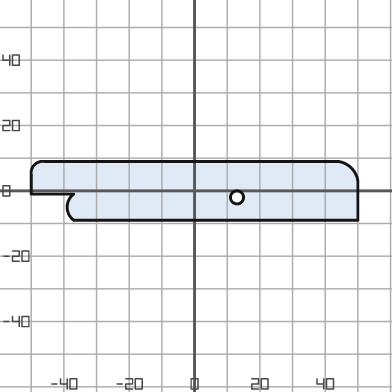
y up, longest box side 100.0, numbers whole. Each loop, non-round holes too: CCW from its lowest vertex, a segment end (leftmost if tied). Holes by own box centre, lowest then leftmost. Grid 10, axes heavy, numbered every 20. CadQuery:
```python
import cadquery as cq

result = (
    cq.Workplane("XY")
    .moveTo(-37.0, -9.0)
    .lineTo(50.0, -9.0)
    .lineTo(50.0, 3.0)
    .threePointArc((48.0, 7.0), (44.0, 9.0))
    .lineTo(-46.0, 9.0)
    .threePointArc((-49.0, 8.0), (-50.0, 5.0))
    .lineTo(-50.0, -1.0)
    .lineTo(-37.0, -1.0)
    .threePointArc((-39.0, -5.0), (-37.0, -9.0))
    .close()
    .moveTo(13.0, -2.0)
    .circle(2.0)
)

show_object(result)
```